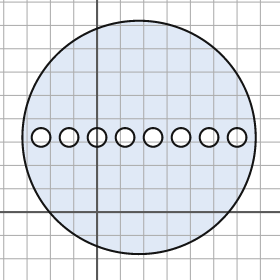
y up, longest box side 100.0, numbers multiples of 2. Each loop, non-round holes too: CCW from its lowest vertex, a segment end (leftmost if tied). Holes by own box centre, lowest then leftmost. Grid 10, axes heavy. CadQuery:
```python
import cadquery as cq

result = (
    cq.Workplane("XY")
    .moveTo(18.0, 32.0)
    .circle(50.0)
    .moveTo(-24.0, 32.0)
    .circle(4.0)
    .moveTo(-12.0, 32.0)
    .circle(4.0)
    .moveTo(0.0, 32.0)
    .circle(4.0)
    .moveTo(12.0, 32.0)
    .circle(4.0)
    .moveTo(24.0, 32.0)
    .circle(4.0)
    .moveTo(36.0, 32.0)
    .circle(4.0)
    .moveTo(48.0, 32.0)
    .circle(4.0)
    .moveTo(60.0, 32.0)
    .circle(4.0)
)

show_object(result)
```